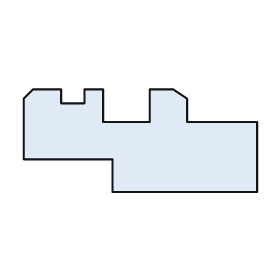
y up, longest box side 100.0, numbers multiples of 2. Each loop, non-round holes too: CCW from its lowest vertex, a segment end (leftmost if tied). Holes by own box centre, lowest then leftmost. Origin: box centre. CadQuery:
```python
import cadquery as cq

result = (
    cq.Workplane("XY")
    .moveTo(-12.0, -22.0)
    .lineTo(50.0, -22.0)
    .lineTo(50.0, 8.0)
    .lineTo(20.0, 8.0)
    .lineTo(20.0, 18.0)
    .lineTo(14.0, 22.0)
    .lineTo(4.0, 22.0)
    .lineTo(4.0, 8.0)
    .lineTo(-16.0, 8.0)
    .lineTo(-16.0, 22.0)
    .lineTo(-24.0, 22.0)
    .lineTo(-24.0, 16.0)
    .lineTo(-34.0, 16.0)
    .lineTo(-34.0, 22.0)
    .lineTo(-46.0, 22.0)
    .lineTo(-50.0, 18.0)
    .lineTo(-50.0, -8.0)
    .lineTo(-12.0, -8.0)
    .close()
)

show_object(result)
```